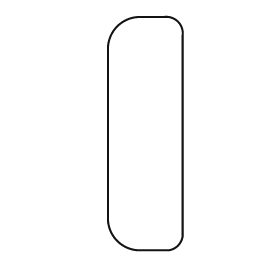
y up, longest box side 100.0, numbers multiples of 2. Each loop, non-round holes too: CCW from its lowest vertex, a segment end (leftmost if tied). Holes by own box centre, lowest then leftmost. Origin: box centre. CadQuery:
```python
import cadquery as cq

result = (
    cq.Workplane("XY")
    .moveTo(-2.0, -50.0)
    .lineTo(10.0, -50.0)
    .threePointArc((14.0, -48.0), (16.0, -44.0))
    .lineTo(16.0, 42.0)
    .threePointArc((14.0, 48.0), (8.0, 50.0))
    .lineTo(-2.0, 50.0)
    .threePointArc((-12.0, 46.0), (-16.0, 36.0))
    .lineTo(-16.0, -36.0)
    .threePointArc((-12.0, -46.0), (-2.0, -50.0))
    .close()
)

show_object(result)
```